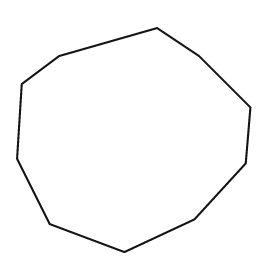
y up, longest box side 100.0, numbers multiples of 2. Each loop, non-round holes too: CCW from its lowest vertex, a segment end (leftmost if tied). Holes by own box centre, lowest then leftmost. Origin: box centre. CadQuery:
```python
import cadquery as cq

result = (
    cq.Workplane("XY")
    .moveTo(-4.0, -48.0)
    .lineTo(26.0, -34.0)
    .lineTo(48.0, -10.0)
    .lineTo(50.0, 14.0)
    .lineTo(28.0, 36.0)
    .lineTo(10.0, 48.0)
    .lineTo(-32.0, 36.0)
    .lineTo(-48.0, 24.0)
    .lineTo(-50.0, -8.0)
    .lineTo(-36.0, -36.0)
    .close()
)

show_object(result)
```